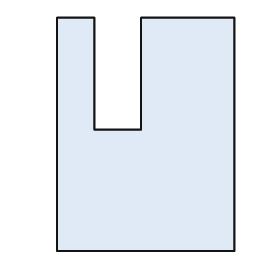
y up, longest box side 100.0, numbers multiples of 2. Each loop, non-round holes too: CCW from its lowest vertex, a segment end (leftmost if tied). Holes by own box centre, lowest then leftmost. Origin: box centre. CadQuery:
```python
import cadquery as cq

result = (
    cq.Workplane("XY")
    .moveTo(-38.0, -50.0)
    .lineTo(38.0, -50.0)
    .lineTo(38.0, 50.0)
    .lineTo(-2.0, 50.0)
    .lineTo(-2.0, 2.0)
    .lineTo(-22.0, 2.0)
    .lineTo(-22.0, 50.0)
    .lineTo(-38.0, 50.0)
    .close()
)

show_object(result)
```